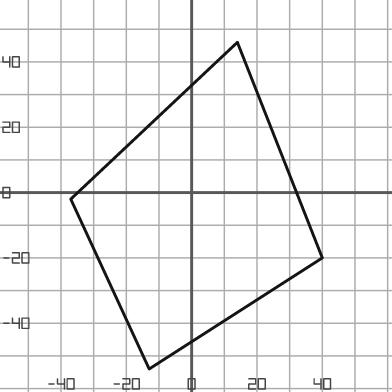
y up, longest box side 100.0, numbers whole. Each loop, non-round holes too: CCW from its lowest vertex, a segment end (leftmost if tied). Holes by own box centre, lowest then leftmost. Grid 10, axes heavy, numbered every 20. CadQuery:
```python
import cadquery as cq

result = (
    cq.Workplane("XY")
    .moveTo(-13.0, -54.0)
    .lineTo(40.0, -20.0)
    .lineTo(14.0, 46.0)
    .lineTo(-37.0, -2.0)
    .close()
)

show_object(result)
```